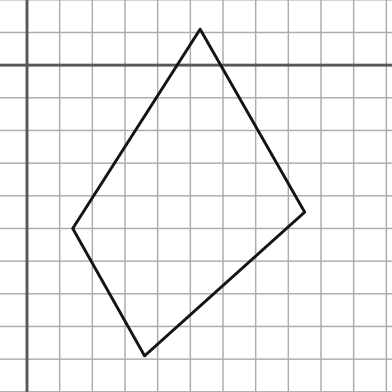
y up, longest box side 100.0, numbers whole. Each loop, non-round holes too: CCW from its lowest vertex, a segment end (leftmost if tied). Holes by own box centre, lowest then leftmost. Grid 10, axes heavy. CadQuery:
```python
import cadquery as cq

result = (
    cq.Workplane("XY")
    .moveTo(36.0, -89.0)
    .lineTo(85.0, -45.0)
    .lineTo(53.0, 11.0)
    .lineTo(14.0, -50.0)
    .close()
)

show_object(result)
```